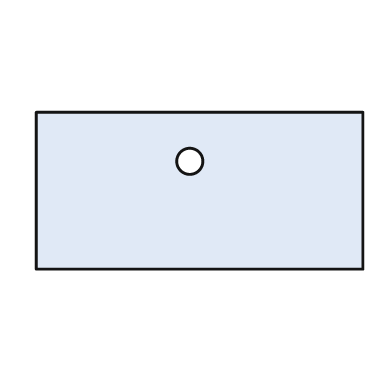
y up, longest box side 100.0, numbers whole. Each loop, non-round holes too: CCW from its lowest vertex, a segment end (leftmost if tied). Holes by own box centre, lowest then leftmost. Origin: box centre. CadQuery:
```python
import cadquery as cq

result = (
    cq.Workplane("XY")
    .moveTo(-50.0, -24.0)
    .lineTo(50.0, -24.0)
    .lineTo(50.0, 24.0)
    .lineTo(-50.0, 24.0)
    .close()
    .moveTo(-3.0, 9.0)
    .circle(4.0)
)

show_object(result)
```